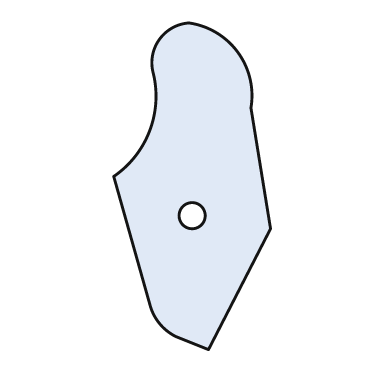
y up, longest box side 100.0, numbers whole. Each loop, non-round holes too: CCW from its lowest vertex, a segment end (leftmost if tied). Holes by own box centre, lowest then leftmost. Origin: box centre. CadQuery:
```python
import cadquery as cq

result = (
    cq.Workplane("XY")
    .moveTo(5.0, -50.0)
    .lineTo(24.0, -13.0)
    .lineTo(18.0, 24.0)
    .threePointArc((14.0, 41.0), (-1.0, 50.0))
    .threePointArc((-10.0, 45.0), (-12.0, 35.0))
    .threePointArc((-13.0, 17.0), (-24.0, 3.0))
    .lineTo(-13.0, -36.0)
    .threePointArc((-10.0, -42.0), (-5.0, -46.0))
    .close()
    .moveTo(0.0, -9.0)
    .circle(4.0)
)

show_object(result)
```